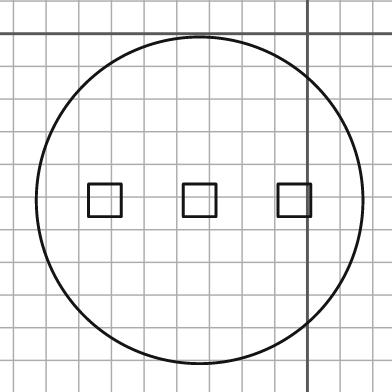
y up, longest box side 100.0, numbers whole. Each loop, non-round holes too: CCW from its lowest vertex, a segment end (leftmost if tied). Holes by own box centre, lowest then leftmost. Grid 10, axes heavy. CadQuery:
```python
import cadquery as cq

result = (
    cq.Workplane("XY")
    .moveTo(-33.0, -51.0)
    .circle(50.0)
    .moveTo(-67.0, -56.0)
    .lineTo(-57.0, -56.0)
    .lineTo(-57.0, -46.0)
    .lineTo(-67.0, -46.0)
    .close()
    .moveTo(-38.0, -56.0)
    .lineTo(-28.0, -56.0)
    .lineTo(-28.0, -46.0)
    .lineTo(-38.0, -46.0)
    .close()
    .moveTo(-9.0, -56.0)
    .lineTo(1.0, -56.0)
    .lineTo(1.0, -46.0)
    .lineTo(-9.0, -46.0)
    .close()
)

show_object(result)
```